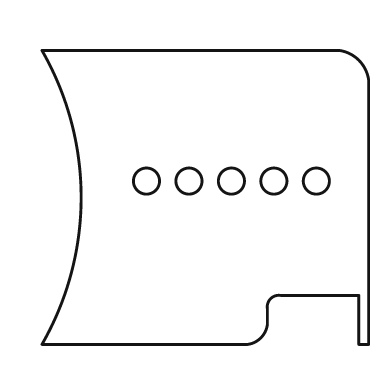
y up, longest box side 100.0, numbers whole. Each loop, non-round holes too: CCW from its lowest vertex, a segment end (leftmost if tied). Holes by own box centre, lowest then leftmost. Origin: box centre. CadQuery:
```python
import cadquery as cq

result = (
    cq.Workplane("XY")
    .moveTo(-50.0, -45.0)
    .lineTo(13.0, -45.0)
    .threePointArc((17.0, -43.0), (19.0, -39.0))
    .lineTo(19.0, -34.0)
    .threePointArc((20.0, -31.0), (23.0, -30.0))
    .lineTo(47.0, -30.0)
    .lineTo(47.0, -45.0)
    .lineTo(50.0, -45.0)
    .lineTo(50.0, 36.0)
    .threePointArc((47.0, 42.0), (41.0, 45.0))
    .lineTo(-50.0, 45.0)
    .threePointArc((-38.0, 0.0), (-50.0, -45.0))
    .close()
    .moveTo(-18.0, 5.0)
    .circle(4.0)
    .moveTo(-5.0, 5.0)
    .circle(4.0)
    .moveTo(8.0, 5.0)
    .circle(4.0)
    .moveTo(21.0, 5.0)
    .circle(4.0)
    .moveTo(34.0, 5.0)
    .circle(4.0)
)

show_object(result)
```